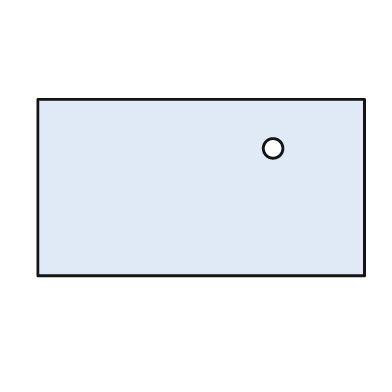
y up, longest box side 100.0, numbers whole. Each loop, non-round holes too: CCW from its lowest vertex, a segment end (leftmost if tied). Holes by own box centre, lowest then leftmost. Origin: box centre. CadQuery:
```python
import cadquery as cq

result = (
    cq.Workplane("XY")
    .moveTo(-50.0, -27.0)
    .lineTo(50.0, -27.0)
    .lineTo(50.0, 27.0)
    .lineTo(-50.0, 27.0)
    .close()
    .moveTo(22.0, 12.0)
    .circle(3.0)
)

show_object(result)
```